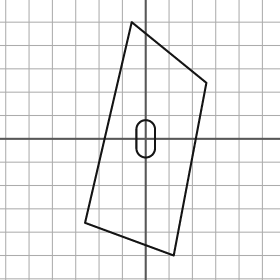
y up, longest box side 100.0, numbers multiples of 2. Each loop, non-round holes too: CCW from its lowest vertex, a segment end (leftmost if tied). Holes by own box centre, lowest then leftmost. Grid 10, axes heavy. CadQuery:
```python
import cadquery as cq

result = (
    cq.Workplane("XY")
    .moveTo(12.0, -50.0)
    .lineTo(26.0, 24.0)
    .lineTo(-6.0, 50.0)
    .lineTo(-26.0, -36.0)
    .close()
    .moveTo(-4.0, -4.0)
    .threePointArc((0.0, -8.0), (4.0, -4.0))
    .lineTo(4.0, 4.0)
    .threePointArc((0.0, 8.0), (-4.0, 4.0))
    .close()
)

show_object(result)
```